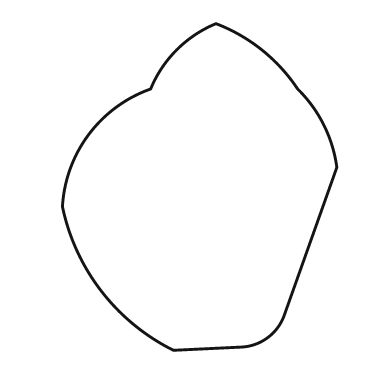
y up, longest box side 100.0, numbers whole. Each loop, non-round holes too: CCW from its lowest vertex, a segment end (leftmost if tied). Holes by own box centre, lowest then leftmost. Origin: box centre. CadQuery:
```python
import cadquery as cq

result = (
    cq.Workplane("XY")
    .moveTo(-8.0, -50.0)
    .lineTo(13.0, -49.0)
    .threePointArc((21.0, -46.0), (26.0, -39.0))
    .lineTo(42.0, 6.0)
    .threePointArc((38.0, 19.0), (30.0, 30.0))
    .threePointArc((19.0, 42.0), (5.0, 50.0))
    .threePointArc((-7.0, 42.0), (-15.0, 30.0))
    .threePointArc((-34.0, 16.0), (-42.0, -6.0))
    .threePointArc((-30.0, -32.0), (-8.0, -50.0))
    .close()
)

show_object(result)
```